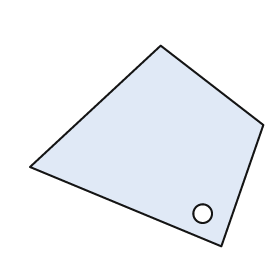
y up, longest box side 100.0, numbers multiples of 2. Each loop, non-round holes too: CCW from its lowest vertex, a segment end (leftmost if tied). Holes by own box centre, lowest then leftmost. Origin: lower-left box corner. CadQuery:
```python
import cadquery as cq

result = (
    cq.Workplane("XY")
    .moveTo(82.0, 0.0)
    .lineTo(100.0, 52.0)
    .lineTo(56.0, 86.0)
    .lineTo(0.0, 34.0)
    .close()
    .moveTo(74.0, 14.0)
    .circle(4.0)
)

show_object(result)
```